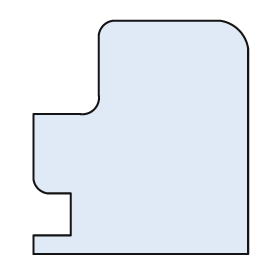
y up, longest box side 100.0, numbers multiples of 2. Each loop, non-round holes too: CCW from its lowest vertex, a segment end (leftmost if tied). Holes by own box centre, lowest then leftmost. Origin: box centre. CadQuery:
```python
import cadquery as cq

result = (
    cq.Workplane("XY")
    .moveTo(-46.0, -50.0)
    .lineTo(46.0, -50.0)
    .lineTo(46.0, 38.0)
    .threePointArc((42.0, 46.0), (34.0, 50.0))
    .lineTo(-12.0, 50.0)
    .threePointArc((-16.0, 48.0), (-18.0, 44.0))
    .lineTo(-18.0, 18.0)
    .threePointArc((-20.0, 12.0), (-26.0, 10.0))
    .lineTo(-46.0, 10.0)
    .lineTo(-46.0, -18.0)
    .threePointArc((-44.0, -22.0), (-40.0, -24.0))
    .lineTo(-30.0, -24.0)
    .lineTo(-30.0, -42.0)
    .lineTo(-46.0, -42.0)
    .close()
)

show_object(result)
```